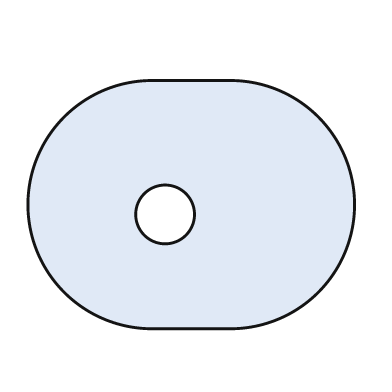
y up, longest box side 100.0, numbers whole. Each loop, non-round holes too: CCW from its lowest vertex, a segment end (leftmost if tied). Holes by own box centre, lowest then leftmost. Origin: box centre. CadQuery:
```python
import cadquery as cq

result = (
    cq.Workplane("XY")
    .moveTo(-12.0, -38.0)
    .lineTo(12.0, -38.0)
    .threePointArc((50.0, 0.0), (12.0, 38.0))
    .lineTo(-12.0, 38.0)
    .threePointArc((-50.0, 0.0), (-12.0, -38.0))
    .close()
    .moveTo(-8.0, -3.0)
    .circle(9.0)
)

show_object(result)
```